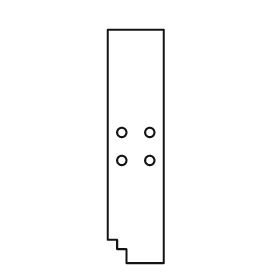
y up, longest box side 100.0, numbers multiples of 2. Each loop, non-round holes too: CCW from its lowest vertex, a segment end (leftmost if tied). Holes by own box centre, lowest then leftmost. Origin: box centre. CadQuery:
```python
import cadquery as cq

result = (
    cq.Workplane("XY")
    .moveTo(-4.0, -50.0)
    .lineTo(12.0, -50.0)
    .lineTo(12.0, 50.0)
    .lineTo(-12.0, 50.0)
    .lineTo(-12.0, -40.0)
    .lineTo(-8.0, -40.0)
    .lineTo(-8.0, -44.0)
    .lineTo(-4.0, -44.0)
    .close()
    .moveTo(-6.0, -6.0)
    .circle(2.0)
    .moveTo(6.0, -6.0)
    .circle(2.0)
    .moveTo(-6.0, 6.0)
    .circle(2.0)
    .moveTo(6.0, 6.0)
    .circle(2.0)
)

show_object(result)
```